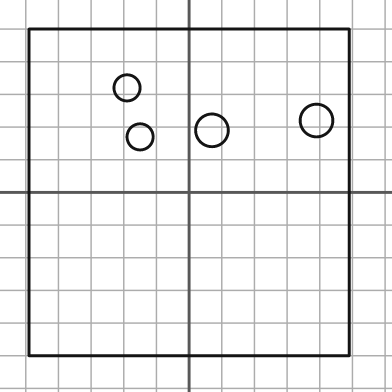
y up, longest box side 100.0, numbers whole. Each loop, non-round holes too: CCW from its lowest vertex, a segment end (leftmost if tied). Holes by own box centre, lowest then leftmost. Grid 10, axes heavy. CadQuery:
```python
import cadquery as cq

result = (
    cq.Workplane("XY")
    .moveTo(-49.0, -50.0)
    .lineTo(49.0, -50.0)
    .lineTo(49.0, 50.0)
    .lineTo(-49.0, 50.0)
    .close()
    .moveTo(-15.0, 17.0)
    .circle(4.0)
    .moveTo(7.0, 19.0)
    .circle(5.0)
    .moveTo(39.0, 22.0)
    .circle(5.0)
    .moveTo(-19.0, 32.0)
    .circle(4.0)
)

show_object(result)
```